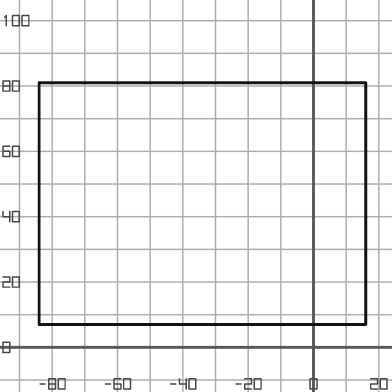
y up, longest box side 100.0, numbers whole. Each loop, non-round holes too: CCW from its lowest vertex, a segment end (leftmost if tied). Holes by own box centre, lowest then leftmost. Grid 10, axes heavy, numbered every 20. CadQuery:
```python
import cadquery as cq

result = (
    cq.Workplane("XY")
    .moveTo(-84.0, 7.0)
    .lineTo(16.0, 7.0)
    .lineTo(16.0, 81.0)
    .lineTo(-84.0, 81.0)
    .close()
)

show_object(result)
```